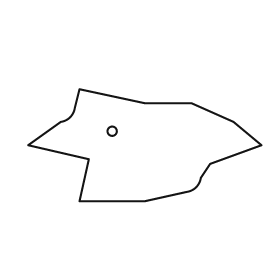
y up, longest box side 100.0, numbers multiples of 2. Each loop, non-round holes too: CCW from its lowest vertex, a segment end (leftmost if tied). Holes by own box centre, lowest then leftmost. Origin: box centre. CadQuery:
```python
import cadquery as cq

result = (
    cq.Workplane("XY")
    .moveTo(-28.0, -24.0)
    .lineTo(0.0, -24.0)
    .lineTo(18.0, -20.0)
    .threePointArc((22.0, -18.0), (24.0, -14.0))
    .lineTo(28.0, -8.0)
    .lineTo(50.0, 0.0)
    .lineTo(38.0, 10.0)
    .lineTo(20.0, 18.0)
    .lineTo(0.0, 18.0)
    .lineTo(-28.0, 24.0)
    .lineTo(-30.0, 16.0)
    .threePointArc((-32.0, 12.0), (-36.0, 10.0))
    .lineTo(-50.0, 0.0)
    .lineTo(-24.0, -6.0)
    .close()
    .moveTo(-14.0, 6.0)
    .circle(2.0)
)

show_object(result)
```